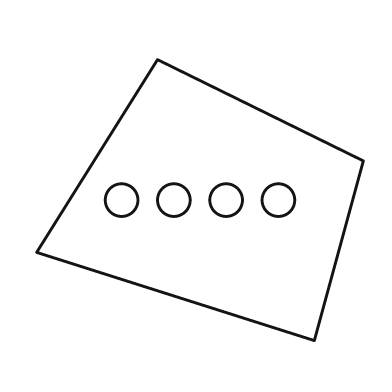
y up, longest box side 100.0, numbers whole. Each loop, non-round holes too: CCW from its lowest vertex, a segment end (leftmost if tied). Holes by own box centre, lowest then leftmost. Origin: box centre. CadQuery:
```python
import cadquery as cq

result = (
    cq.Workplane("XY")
    .moveTo(35.0, -43.0)
    .lineTo(50.0, 12.0)
    .lineTo(-13.0, 43.0)
    .lineTo(-50.0, -16.0)
    .close()
    .moveTo(-24.0, 0.0)
    .circle(5.0)
    .moveTo(-8.0, 0.0)
    .circle(5.0)
    .moveTo(8.0, 0.0)
    .circle(5.0)
    .moveTo(24.0, 0.0)
    .circle(5.0)
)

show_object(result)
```